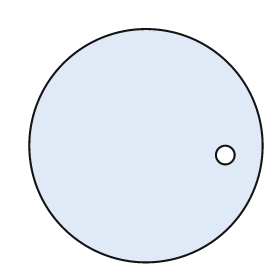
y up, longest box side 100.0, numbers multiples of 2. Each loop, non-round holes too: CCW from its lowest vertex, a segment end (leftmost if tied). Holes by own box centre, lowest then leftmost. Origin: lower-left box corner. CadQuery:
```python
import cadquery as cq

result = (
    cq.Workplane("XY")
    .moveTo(50.0, 50.0)
    .circle(50.0)
    .moveTo(84.0, 46.0)
    .circle(4.0)
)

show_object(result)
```